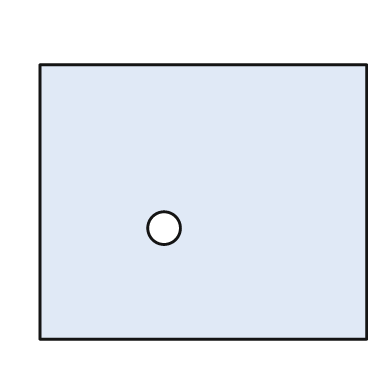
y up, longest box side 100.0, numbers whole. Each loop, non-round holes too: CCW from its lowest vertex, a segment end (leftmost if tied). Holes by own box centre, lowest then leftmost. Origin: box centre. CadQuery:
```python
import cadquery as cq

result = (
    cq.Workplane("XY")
    .moveTo(-50.0, -42.0)
    .lineTo(50.0, -42.0)
    .lineTo(50.0, 42.0)
    .lineTo(-50.0, 42.0)
    .close()
    .moveTo(-12.0, -8.0)
    .circle(5.0)
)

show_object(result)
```